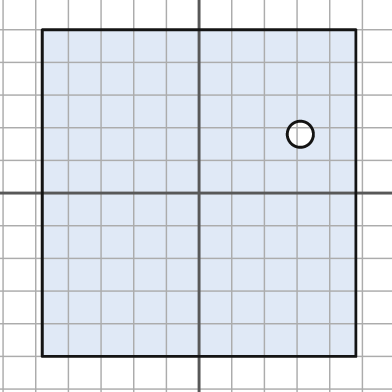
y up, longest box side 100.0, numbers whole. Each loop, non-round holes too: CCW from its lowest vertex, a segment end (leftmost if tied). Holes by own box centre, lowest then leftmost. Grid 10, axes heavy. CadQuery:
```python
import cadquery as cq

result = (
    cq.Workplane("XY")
    .moveTo(-48.0, -50.0)
    .lineTo(48.0, -50.0)
    .lineTo(48.0, 50.0)
    .lineTo(-48.0, 50.0)
    .close()
    .moveTo(31.0, 18.0)
    .circle(4.0)
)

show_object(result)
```